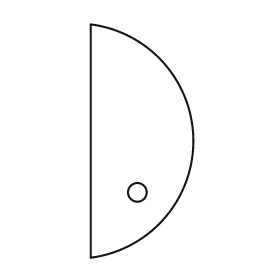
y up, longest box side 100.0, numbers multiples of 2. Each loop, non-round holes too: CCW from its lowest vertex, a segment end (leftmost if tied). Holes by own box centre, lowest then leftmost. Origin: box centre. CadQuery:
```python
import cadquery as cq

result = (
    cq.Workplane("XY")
    .moveTo(-22.0, -50.0)
    .threePointArc((22.0, 0.0), (-22.0, 50.0))
    .close()
    .moveTo(-2.0, -22.0)
    .circle(4.0)
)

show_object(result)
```